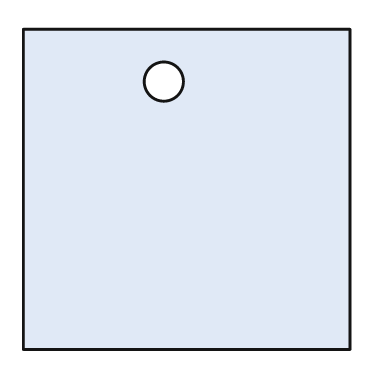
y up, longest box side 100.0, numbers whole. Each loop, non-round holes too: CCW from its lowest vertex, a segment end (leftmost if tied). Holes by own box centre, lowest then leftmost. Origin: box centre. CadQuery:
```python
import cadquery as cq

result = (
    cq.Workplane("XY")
    .moveTo(-50.0, -49.0)
    .lineTo(50.0, -49.0)
    .lineTo(50.0, 49.0)
    .lineTo(-50.0, 49.0)
    .close()
    .moveTo(-7.0, 33.0)
    .circle(6.0)
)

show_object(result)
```